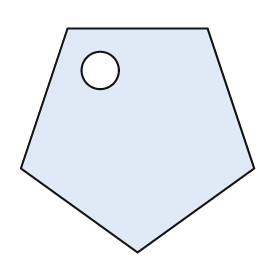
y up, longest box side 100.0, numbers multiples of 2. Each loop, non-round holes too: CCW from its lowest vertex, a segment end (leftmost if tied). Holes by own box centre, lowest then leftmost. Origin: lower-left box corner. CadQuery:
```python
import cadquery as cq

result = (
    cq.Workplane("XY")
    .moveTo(50.0, 0.0)
    .lineTo(100.0, 36.0)
    .lineTo(80.0, 96.0)
    .lineTo(20.0, 96.0)
    .lineTo(0.0, 36.0)
    .close()
    .moveTo(34.0, 78.0)
    .circle(8.0)
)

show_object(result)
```